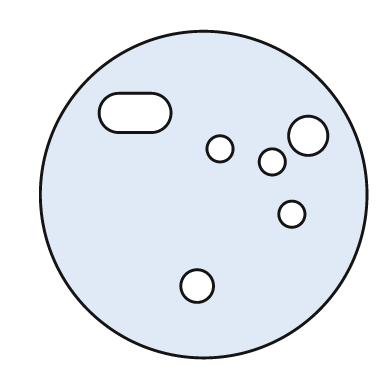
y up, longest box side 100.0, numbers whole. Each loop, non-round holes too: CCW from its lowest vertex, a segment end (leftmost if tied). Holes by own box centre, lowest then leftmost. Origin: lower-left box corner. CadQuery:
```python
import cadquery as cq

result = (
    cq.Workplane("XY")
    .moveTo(50.0, 50.0)
    .circle(50.0)
    .moveTo(48.0, 22.0)
    .circle(5.0)
    .moveTo(77.0, 44.0)
    .circle(4.0)
    .moveTo(71.0, 60.0)
    .circle(4.0)
    .moveTo(55.0, 64.0)
    .circle(4.0)
    .moveTo(82.0, 68.0)
    .circle(6.0)
    .moveTo(24.0, 69.0)
    .lineTo(34.0, 69.0)
    .threePointArc((40.0, 75.0), (34.0, 81.0))
    .lineTo(24.0, 81.0)
    .threePointArc((18.0, 75.0), (24.0, 69.0))
    .close()
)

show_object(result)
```